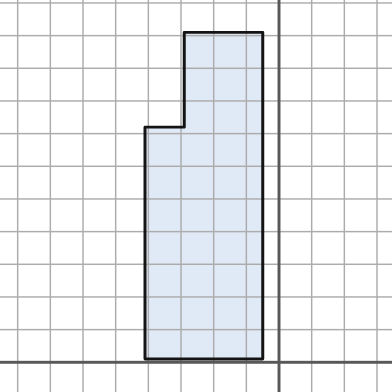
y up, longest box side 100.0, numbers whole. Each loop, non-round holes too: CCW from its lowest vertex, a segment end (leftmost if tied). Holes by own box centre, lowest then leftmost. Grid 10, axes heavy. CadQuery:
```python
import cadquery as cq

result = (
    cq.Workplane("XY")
    .moveTo(-41.0, 1.0)
    .lineTo(-5.0, 1.0)
    .lineTo(-5.0, 101.0)
    .lineTo(-29.0, 101.0)
    .lineTo(-29.0, 72.0)
    .lineTo(-41.0, 72.0)
    .close()
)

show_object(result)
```